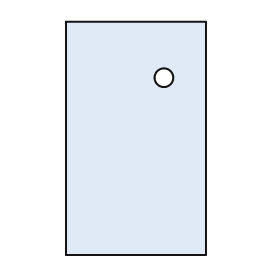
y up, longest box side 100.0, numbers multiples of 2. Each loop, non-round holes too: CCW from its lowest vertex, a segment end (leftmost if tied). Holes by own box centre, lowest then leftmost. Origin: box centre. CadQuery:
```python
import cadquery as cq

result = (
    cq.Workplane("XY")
    .moveTo(-30.0, -50.0)
    .lineTo(30.0, -50.0)
    .lineTo(30.0, 50.0)
    .lineTo(-30.0, 50.0)
    .close()
    .moveTo(12.0, 26.0)
    .circle(4.0)
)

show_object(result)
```